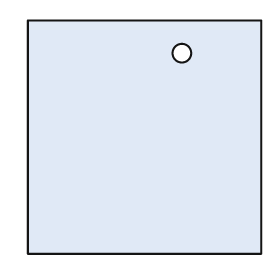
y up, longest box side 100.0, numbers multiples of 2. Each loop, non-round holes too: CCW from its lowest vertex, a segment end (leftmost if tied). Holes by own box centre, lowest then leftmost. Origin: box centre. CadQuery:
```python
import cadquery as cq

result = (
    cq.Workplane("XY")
    .moveTo(-50.0, -50.0)
    .lineTo(50.0, -50.0)
    .lineTo(50.0, 50.0)
    .lineTo(-50.0, 50.0)
    .close()
    .moveTo(16.0, 36.0)
    .circle(4.0)
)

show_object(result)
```